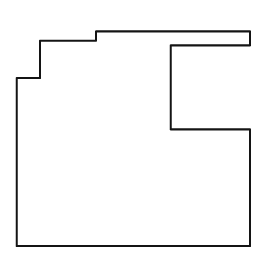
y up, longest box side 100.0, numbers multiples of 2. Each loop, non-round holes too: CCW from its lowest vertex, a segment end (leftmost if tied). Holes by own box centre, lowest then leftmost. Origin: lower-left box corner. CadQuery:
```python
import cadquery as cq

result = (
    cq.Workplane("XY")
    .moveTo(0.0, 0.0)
    .lineTo(100.0, 0.0)
    .lineTo(100.0, 50.0)
    .lineTo(66.0, 50.0)
    .lineTo(66.0, 86.0)
    .lineTo(100.0, 86.0)
    .lineTo(100.0, 92.0)
    .lineTo(34.0, 92.0)
    .lineTo(34.0, 88.0)
    .lineTo(10.0, 88.0)
    .lineTo(10.0, 72.0)
    .lineTo(0.0, 72.0)
    .close()
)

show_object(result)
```